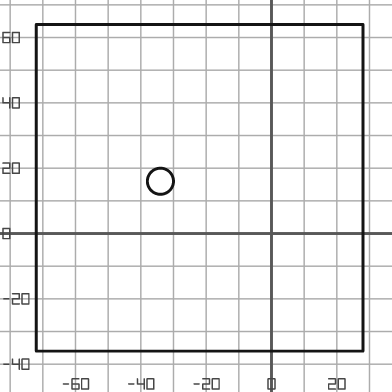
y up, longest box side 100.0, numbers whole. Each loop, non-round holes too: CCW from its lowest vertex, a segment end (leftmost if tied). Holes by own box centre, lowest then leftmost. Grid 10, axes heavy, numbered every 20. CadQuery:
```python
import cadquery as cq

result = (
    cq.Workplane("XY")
    .moveTo(-72.0, -36.0)
    .lineTo(28.0, -36.0)
    .lineTo(28.0, 64.0)
    .lineTo(-72.0, 64.0)
    .close()
    .moveTo(-34.0, 16.0)
    .circle(4.0)
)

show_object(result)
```